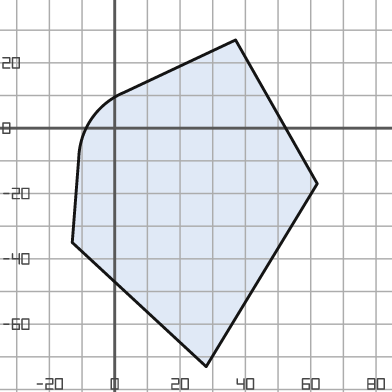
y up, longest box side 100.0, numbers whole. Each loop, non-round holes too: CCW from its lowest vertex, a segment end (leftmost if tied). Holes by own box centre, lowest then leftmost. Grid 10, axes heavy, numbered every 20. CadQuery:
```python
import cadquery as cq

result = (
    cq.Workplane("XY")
    .moveTo(28.0, -73.0)
    .lineTo(62.0, -17.0)
    .lineTo(37.0, 27.0)
    .lineTo(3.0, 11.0)
    .threePointArc((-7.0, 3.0), (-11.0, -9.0))
    .lineTo(-13.0, -35.0)
    .close()
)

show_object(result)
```